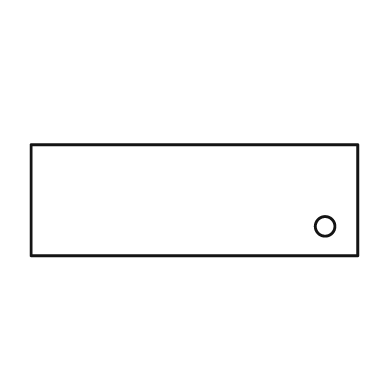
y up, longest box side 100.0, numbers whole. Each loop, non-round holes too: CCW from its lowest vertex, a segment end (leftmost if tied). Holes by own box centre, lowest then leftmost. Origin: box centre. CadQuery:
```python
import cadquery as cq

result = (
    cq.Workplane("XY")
    .moveTo(-50.0, -17.0)
    .lineTo(50.0, -17.0)
    .lineTo(50.0, 17.0)
    .lineTo(-50.0, 17.0)
    .close()
    .moveTo(40.0, -8.0)
    .circle(3.0)
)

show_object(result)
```